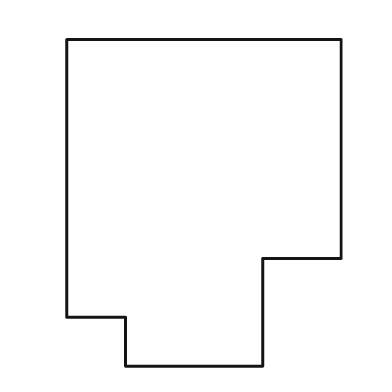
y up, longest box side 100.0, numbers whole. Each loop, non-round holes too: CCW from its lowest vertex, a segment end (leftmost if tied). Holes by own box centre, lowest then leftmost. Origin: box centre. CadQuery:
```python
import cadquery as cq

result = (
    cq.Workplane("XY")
    .moveTo(-24.0, -50.0)
    .lineTo(18.0, -50.0)
    .lineTo(18.0, -17.0)
    .lineTo(42.0, -17.0)
    .lineTo(42.0, 50.0)
    .lineTo(-42.0, 50.0)
    .lineTo(-42.0, -35.0)
    .lineTo(-24.0, -35.0)
    .close()
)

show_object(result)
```